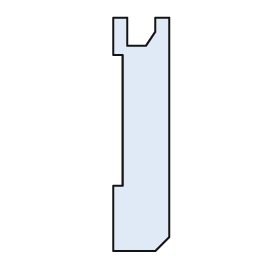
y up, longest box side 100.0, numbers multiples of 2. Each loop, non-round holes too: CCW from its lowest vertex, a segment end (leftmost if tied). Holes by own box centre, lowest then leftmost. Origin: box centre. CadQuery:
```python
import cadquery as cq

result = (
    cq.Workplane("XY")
    .moveTo(-12.0, -50.0)
    .lineTo(6.0, -50.0)
    .lineTo(12.0, -44.0)
    .lineTo(12.0, 50.0)
    .lineTo(6.0, 50.0)
    .lineTo(6.0, 44.0)
    .lineTo(2.0, 38.0)
    .lineTo(-6.0, 38.0)
    .lineTo(-6.0, 50.0)
    .lineTo(-12.0, 50.0)
    .lineTo(-12.0, 34.0)
    .lineTo(-8.0, 34.0)
    .lineTo(-8.0, -22.0)
    .lineTo(-12.0, -22.0)
    .close()
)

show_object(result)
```